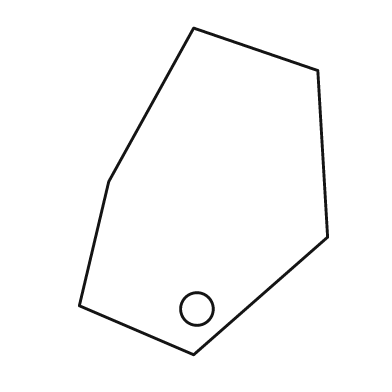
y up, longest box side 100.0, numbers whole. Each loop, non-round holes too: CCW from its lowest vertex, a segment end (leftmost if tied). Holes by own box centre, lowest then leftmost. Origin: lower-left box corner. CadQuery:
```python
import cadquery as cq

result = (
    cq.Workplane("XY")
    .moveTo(35.0, 0.0)
    .lineTo(76.0, 36.0)
    .lineTo(73.0, 87.0)
    .lineTo(35.0, 100.0)
    .lineTo(9.0, 53.0)
    .lineTo(0.0, 15.0)
    .close()
    .moveTo(36.0, 14.0)
    .circle(5.0)
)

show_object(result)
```